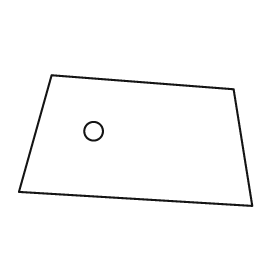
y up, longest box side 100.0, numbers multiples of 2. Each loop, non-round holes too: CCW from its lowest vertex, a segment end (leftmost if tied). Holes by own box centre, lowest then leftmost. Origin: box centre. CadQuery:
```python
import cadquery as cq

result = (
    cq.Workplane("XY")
    .moveTo(50.0, -28.0)
    .lineTo(42.0, 22.0)
    .lineTo(-36.0, 28.0)
    .lineTo(-50.0, -22.0)
    .close()
    .moveTo(-18.0, 4.0)
    .circle(4.0)
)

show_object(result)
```